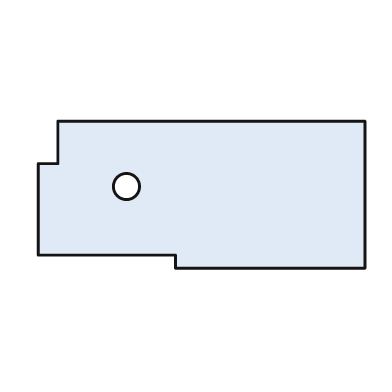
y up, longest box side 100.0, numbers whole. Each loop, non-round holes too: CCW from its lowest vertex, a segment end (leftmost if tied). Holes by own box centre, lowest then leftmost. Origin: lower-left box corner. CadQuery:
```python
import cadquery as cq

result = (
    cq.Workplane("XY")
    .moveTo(42.0, 0.0)
    .lineTo(100.0, 0.0)
    .lineTo(100.0, 45.0)
    .lineTo(6.0, 45.0)
    .lineTo(6.0, 32.0)
    .lineTo(0.0, 32.0)
    .lineTo(0.0, 4.0)
    .lineTo(42.0, 4.0)
    .close()
    .moveTo(27.0, 25.0)
    .circle(4.0)
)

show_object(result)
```